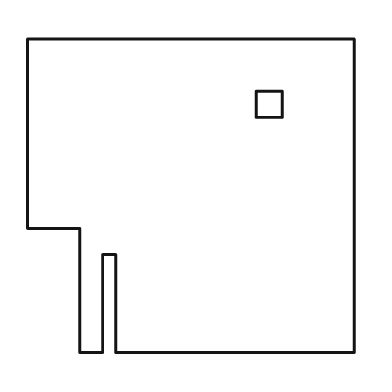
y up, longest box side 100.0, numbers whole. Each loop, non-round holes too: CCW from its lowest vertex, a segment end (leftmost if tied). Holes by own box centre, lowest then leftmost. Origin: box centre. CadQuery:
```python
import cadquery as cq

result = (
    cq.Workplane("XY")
    .moveTo(-34.0, -48.0)
    .lineTo(-27.0, -48.0)
    .lineTo(-27.0, -18.0)
    .lineTo(-23.0, -18.0)
    .lineTo(-23.0, -48.0)
    .lineTo(50.0, -48.0)
    .lineTo(50.0, 48.0)
    .lineTo(-50.0, 48.0)
    .lineTo(-50.0, -10.0)
    .lineTo(-34.0, -10.0)
    .close()
    .moveTo(20.0, 24.0)
    .lineTo(28.0, 24.0)
    .lineTo(28.0, 32.0)
    .lineTo(20.0, 32.0)
    .close()
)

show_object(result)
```